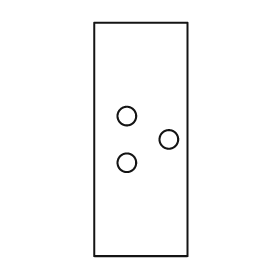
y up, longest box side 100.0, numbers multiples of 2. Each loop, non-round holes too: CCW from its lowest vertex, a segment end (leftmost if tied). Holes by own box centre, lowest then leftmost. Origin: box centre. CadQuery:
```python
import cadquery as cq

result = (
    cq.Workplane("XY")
    .moveTo(-20.0, -50.0)
    .lineTo(20.0, -50.0)
    .lineTo(20.0, 50.0)
    .lineTo(-20.0, 50.0)
    .close()
    .moveTo(-6.0, -10.0)
    .circle(4.0)
    .moveTo(12.0, 0.0)
    .circle(4.0)
    .moveTo(-6.0, 10.0)
    .circle(4.0)
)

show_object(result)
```